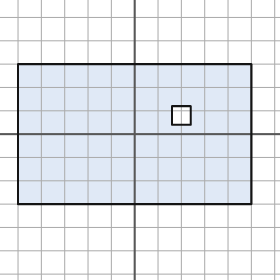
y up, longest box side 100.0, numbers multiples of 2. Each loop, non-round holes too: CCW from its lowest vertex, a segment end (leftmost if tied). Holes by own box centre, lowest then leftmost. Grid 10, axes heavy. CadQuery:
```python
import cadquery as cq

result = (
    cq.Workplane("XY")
    .moveTo(-50.0, -30.0)
    .lineTo(50.0, -30.0)
    .lineTo(50.0, 30.0)
    .lineTo(-50.0, 30.0)
    .close()
    .moveTo(16.0, 4.0)
    .lineTo(24.0, 4.0)
    .lineTo(24.0, 12.0)
    .lineTo(16.0, 12.0)
    .close()
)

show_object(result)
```